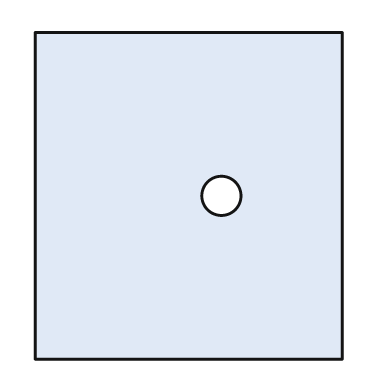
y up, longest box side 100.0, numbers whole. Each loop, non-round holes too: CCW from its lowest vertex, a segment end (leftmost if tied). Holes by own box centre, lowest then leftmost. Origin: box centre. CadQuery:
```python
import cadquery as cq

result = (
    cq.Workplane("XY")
    .moveTo(-47.0, -50.0)
    .lineTo(47.0, -50.0)
    .lineTo(47.0, 50.0)
    .lineTo(-47.0, 50.0)
    .close()
    .moveTo(10.0, 0.0)
    .circle(6.0)
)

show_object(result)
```